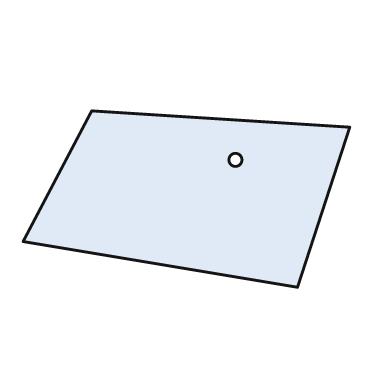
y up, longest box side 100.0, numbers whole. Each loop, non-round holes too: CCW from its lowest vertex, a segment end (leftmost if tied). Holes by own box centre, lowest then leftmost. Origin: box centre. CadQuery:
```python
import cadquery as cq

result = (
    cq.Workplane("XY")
    .moveTo(34.0, -27.0)
    .lineTo(50.0, 22.0)
    .lineTo(-29.0, 27.0)
    .lineTo(-50.0, -13.0)
    .close()
    .moveTo(15.0, 12.0)
    .circle(2.0)
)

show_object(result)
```